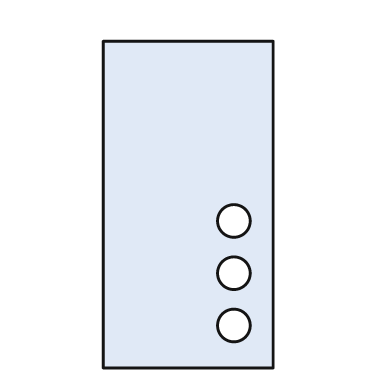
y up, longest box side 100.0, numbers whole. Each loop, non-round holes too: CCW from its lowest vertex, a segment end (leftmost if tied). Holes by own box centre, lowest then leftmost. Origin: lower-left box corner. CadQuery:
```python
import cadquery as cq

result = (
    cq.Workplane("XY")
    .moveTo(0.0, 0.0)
    .lineTo(52.0, 0.0)
    .lineTo(52.0, 100.0)
    .lineTo(0.0, 100.0)
    .close()
    .moveTo(40.0, 13.0)
    .circle(5.0)
    .moveTo(40.0, 29.0)
    .circle(5.0)
    .moveTo(40.0, 45.0)
    .circle(5.0)
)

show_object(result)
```